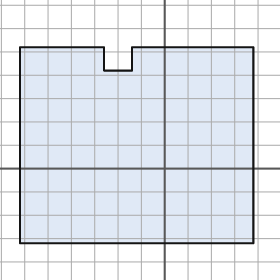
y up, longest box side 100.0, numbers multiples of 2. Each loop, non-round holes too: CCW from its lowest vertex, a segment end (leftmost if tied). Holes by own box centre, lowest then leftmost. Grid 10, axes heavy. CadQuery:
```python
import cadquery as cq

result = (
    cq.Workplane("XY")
    .moveTo(-62.0, -32.0)
    .lineTo(38.0, -32.0)
    .lineTo(38.0, 52.0)
    .lineTo(-14.0, 52.0)
    .lineTo(-14.0, 42.0)
    .lineTo(-26.0, 42.0)
    .lineTo(-26.0, 52.0)
    .lineTo(-62.0, 52.0)
    .close()
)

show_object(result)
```